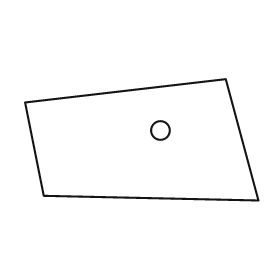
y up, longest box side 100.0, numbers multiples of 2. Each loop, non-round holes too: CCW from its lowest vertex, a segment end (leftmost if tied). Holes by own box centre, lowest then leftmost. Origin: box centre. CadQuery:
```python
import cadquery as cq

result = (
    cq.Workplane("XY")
    .moveTo(50.0, -26.0)
    .lineTo(36.0, 26.0)
    .lineTo(-50.0, 16.0)
    .lineTo(-42.0, -24.0)
    .close()
    .moveTo(8.0, 4.0)
    .circle(4.0)
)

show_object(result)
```